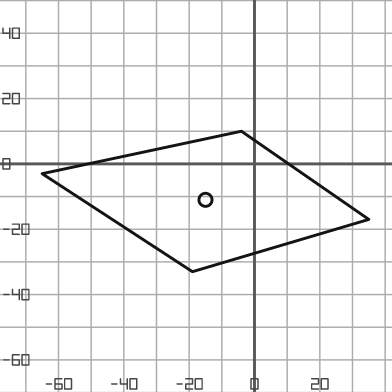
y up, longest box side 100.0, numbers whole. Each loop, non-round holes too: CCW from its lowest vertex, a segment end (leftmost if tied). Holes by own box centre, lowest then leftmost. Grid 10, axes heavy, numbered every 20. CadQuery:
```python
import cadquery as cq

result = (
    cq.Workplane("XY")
    .moveTo(-19.0, -33.0)
    .lineTo(35.0, -17.0)
    .lineTo(-4.0, 10.0)
    .lineTo(-65.0, -3.0)
    .close()
    .moveTo(-15.0, -11.0)
    .circle(2.0)
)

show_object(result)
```